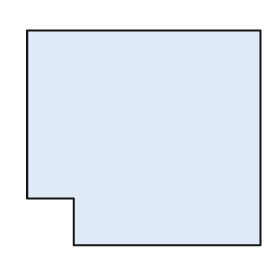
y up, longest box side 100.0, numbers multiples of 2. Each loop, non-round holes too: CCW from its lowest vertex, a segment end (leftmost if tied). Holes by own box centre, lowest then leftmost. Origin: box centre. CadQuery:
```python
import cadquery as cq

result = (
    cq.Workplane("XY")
    .moveTo(-30.0, -46.0)
    .lineTo(50.0, -46.0)
    .lineTo(50.0, 46.0)
    .lineTo(-50.0, 46.0)
    .lineTo(-50.0, -26.0)
    .lineTo(-30.0, -26.0)
    .close()
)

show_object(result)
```